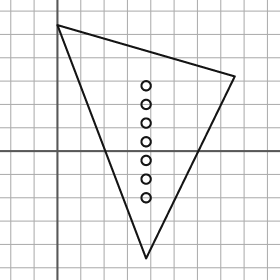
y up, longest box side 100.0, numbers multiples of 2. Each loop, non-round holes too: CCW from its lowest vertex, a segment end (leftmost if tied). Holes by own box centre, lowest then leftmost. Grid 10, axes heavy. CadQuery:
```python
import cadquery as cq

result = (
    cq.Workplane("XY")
    .moveTo(38.0, -46.0)
    .lineTo(76.0, 32.0)
    .lineTo(0.0, 54.0)
    .close()
    .moveTo(38.0, -20.0)
    .circle(2.0)
    .moveTo(38.0, -12.0)
    .circle(2.0)
    .moveTo(38.0, -4.0)
    .circle(2.0)
    .moveTo(38.0, 4.0)
    .circle(2.0)
    .moveTo(38.0, 12.0)
    .circle(2.0)
    .moveTo(38.0, 20.0)
    .circle(2.0)
    .moveTo(38.0, 28.0)
    .circle(2.0)
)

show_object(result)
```